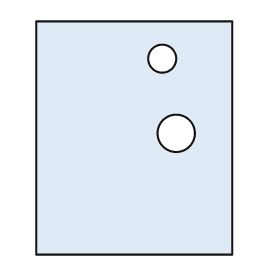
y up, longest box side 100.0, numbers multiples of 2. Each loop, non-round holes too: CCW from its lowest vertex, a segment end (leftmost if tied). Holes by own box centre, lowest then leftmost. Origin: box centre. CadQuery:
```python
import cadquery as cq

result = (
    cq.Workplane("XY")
    .moveTo(-42.0, -50.0)
    .lineTo(42.0, -50.0)
    .lineTo(42.0, 50.0)
    .lineTo(-42.0, 50.0)
    .close()
    .moveTo(18.0, 2.0)
    .circle(8.0)
    .moveTo(12.0, 34.0)
    .circle(6.0)
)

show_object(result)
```